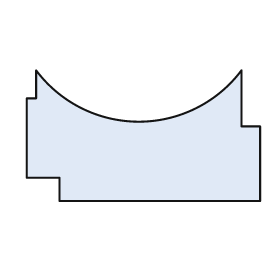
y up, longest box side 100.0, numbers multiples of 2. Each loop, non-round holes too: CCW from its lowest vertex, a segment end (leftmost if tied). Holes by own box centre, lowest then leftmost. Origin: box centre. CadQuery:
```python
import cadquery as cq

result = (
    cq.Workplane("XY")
    .moveTo(-36.0, -28.0)
    .lineTo(50.0, -28.0)
    .lineTo(50.0, 4.0)
    .lineTo(42.0, 4.0)
    .lineTo(42.0, 28.0)
    .threePointArc((-2.0, 6.0), (-46.0, 28.0))
    .lineTo(-46.0, 16.0)
    .lineTo(-50.0, 16.0)
    .lineTo(-50.0, -18.0)
    .lineTo(-36.0, -18.0)
    .close()
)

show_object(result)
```